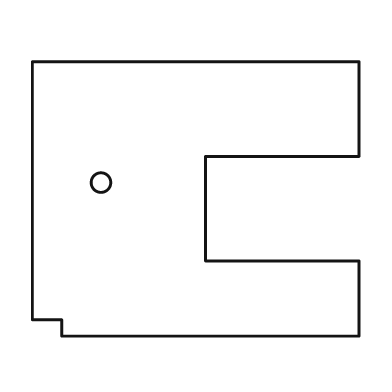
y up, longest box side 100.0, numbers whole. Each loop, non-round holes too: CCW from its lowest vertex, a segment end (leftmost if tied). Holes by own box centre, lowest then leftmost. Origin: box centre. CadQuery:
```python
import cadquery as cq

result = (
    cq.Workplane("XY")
    .moveTo(-41.0, -42.0)
    .lineTo(50.0, -42.0)
    .lineTo(50.0, -19.0)
    .lineTo(3.0, -19.0)
    .lineTo(3.0, 13.0)
    .lineTo(50.0, 13.0)
    .lineTo(50.0, 42.0)
    .lineTo(-50.0, 42.0)
    .lineTo(-50.0, -37.0)
    .lineTo(-41.0, -37.0)
    .close()
    .moveTo(-29.0, 5.0)
    .circle(3.0)
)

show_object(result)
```